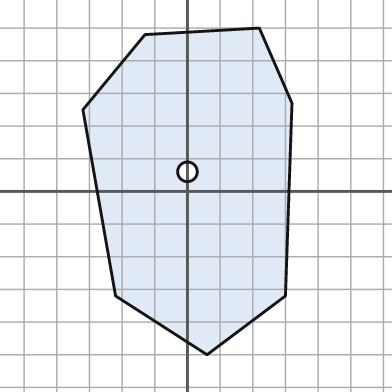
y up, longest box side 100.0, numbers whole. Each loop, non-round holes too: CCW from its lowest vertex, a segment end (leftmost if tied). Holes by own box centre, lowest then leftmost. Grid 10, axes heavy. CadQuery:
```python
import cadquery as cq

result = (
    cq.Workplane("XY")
    .moveTo(6.0, -50.0)
    .lineTo(30.0, -32.0)
    .lineTo(32.0, 27.0)
    .lineTo(22.0, 50.0)
    .lineTo(-13.0, 48.0)
    .lineTo(-32.0, 25.0)
    .lineTo(-22.0, -32.0)
    .close()
    .moveTo(0.0, 6.0)
    .circle(3.0)
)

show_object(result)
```